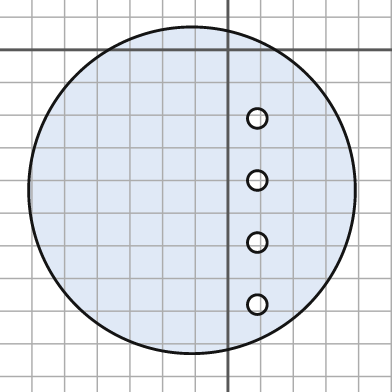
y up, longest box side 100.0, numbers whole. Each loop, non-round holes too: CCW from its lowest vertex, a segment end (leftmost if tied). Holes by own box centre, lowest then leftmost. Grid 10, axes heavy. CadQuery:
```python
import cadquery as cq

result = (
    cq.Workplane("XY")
    .moveTo(-11.0, -43.0)
    .circle(50.0)
    .moveTo(9.0, -78.0)
    .circle(3.0)
    .moveTo(9.0, -59.0)
    .circle(3.0)
    .moveTo(9.0, -40.0)
    .circle(3.0)
    .moveTo(9.0, -21.0)
    .circle(3.0)
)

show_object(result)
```